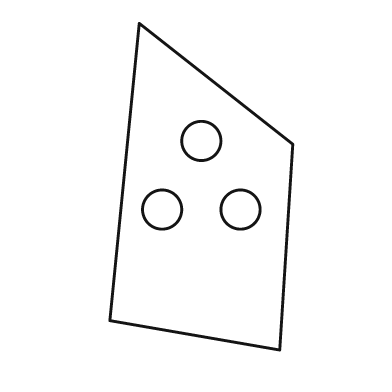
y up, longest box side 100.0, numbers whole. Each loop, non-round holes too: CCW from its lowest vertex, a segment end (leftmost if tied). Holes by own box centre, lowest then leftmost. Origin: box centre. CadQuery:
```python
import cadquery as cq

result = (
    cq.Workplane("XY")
    .moveTo(24.0, -50.0)
    .lineTo(28.0, 13.0)
    .lineTo(-19.0, 50.0)
    .lineTo(-28.0, -41.0)
    .close()
    .moveTo(-12.0, -7.0)
    .circle(6.0)
    .moveTo(12.0, -7.0)
    .circle(6.0)
    .moveTo(0.0, 14.0)
    .circle(6.0)
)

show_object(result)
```